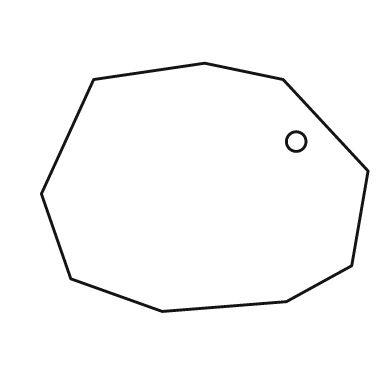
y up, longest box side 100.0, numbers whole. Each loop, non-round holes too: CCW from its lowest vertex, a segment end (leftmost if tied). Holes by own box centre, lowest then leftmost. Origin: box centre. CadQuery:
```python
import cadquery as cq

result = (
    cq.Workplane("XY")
    .moveTo(-13.0, -38.0)
    .lineTo(25.0, -35.0)
    .lineTo(45.0, -24.0)
    .lineTo(50.0, 5.0)
    .lineTo(24.0, 33.0)
    .lineTo(0.0, 38.0)
    .lineTo(-34.0, 33.0)
    .lineTo(-50.0, -2.0)
    .lineTo(-41.0, -28.0)
    .close()
    .moveTo(28.0, 14.0)
    .circle(3.0)
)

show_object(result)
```